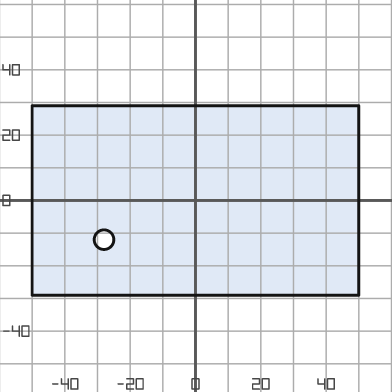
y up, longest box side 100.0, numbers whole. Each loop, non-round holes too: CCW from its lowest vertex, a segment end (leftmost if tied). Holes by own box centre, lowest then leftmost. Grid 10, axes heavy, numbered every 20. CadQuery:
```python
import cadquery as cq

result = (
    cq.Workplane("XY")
    .moveTo(-50.0, -29.0)
    .lineTo(50.0, -29.0)
    .lineTo(50.0, 29.0)
    .lineTo(-50.0, 29.0)
    .close()
    .moveTo(-28.0, -12.0)
    .circle(3.0)
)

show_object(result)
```